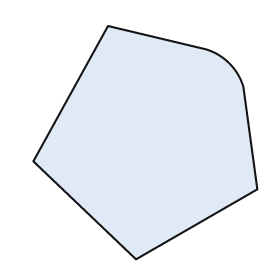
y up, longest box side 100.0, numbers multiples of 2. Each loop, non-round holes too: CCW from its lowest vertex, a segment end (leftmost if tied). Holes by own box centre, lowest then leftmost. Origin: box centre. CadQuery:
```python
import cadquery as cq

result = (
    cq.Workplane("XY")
    .moveTo(-4.0, -50.0)
    .lineTo(48.0, -20.0)
    .lineTo(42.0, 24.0)
    .threePointArc((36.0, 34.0), (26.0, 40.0))
    .lineTo(-16.0, 50.0)
    .lineTo(-48.0, -8.0)
    .close()
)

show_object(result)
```